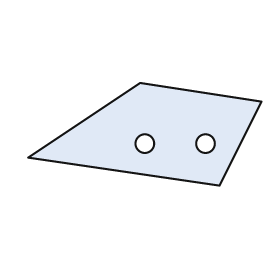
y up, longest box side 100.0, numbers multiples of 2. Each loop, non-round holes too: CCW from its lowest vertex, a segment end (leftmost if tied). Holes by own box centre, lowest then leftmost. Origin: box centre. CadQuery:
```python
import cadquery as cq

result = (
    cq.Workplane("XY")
    .moveTo(32.0, -22.0)
    .lineTo(50.0, 14.0)
    .lineTo(-2.0, 22.0)
    .lineTo(-50.0, -10.0)
    .close()
    .moveTo(0.0, -4.0)
    .circle(4.0)
    .moveTo(26.0, -4.0)
    .circle(4.0)
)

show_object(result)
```